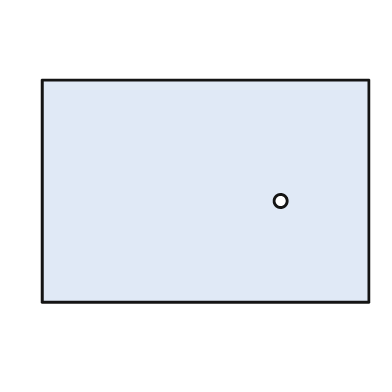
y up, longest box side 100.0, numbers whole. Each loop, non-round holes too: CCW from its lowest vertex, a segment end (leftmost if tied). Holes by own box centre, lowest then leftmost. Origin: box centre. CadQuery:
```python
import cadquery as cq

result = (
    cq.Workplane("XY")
    .moveTo(-50.0, -34.0)
    .lineTo(50.0, -34.0)
    .lineTo(50.0, 34.0)
    .lineTo(-50.0, 34.0)
    .close()
    .moveTo(23.0, -3.0)
    .circle(2.0)
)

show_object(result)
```